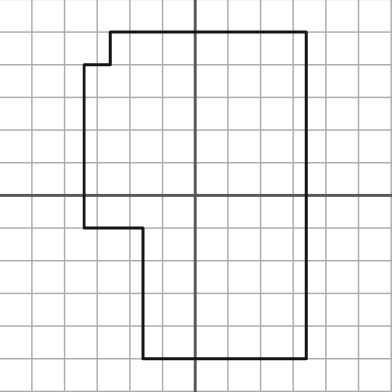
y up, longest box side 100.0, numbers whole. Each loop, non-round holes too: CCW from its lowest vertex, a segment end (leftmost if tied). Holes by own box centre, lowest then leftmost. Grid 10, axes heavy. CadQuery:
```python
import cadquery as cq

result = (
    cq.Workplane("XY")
    .moveTo(-16.0, -50.0)
    .lineTo(34.0, -50.0)
    .lineTo(34.0, 50.0)
    .lineTo(-26.0, 50.0)
    .lineTo(-26.0, 40.0)
    .lineTo(-34.0, 40.0)
    .lineTo(-34.0, -10.0)
    .lineTo(-16.0, -10.0)
    .close()
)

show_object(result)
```